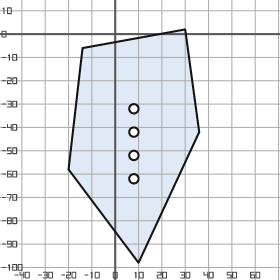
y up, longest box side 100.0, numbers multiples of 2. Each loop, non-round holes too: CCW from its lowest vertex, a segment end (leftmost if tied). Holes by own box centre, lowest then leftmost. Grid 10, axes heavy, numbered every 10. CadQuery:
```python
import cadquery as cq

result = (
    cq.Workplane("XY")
    .moveTo(10.0, -98.0)
    .lineTo(36.0, -42.0)
    .lineTo(30.0, 2.0)
    .lineTo(-14.0, -6.0)
    .lineTo(-20.0, -58.0)
    .close()
    .moveTo(8.0, -62.0)
    .circle(2.0)
    .moveTo(8.0, -52.0)
    .circle(2.0)
    .moveTo(8.0, -42.0)
    .circle(2.0)
    .moveTo(8.0, -32.0)
    .circle(2.0)
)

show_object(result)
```